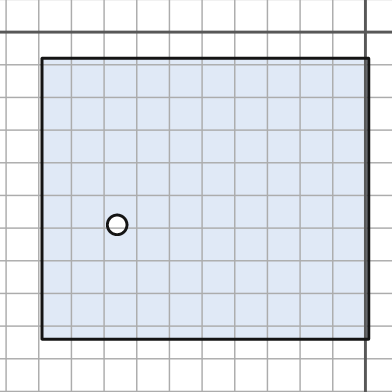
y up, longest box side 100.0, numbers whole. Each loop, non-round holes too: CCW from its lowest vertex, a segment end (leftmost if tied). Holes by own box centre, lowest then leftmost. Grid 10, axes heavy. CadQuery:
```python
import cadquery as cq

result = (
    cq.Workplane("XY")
    .moveTo(-99.0, -94.0)
    .lineTo(1.0, -94.0)
    .lineTo(1.0, -8.0)
    .lineTo(-99.0, -8.0)
    .close()
    .moveTo(-76.0, -59.0)
    .circle(3.0)
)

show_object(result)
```